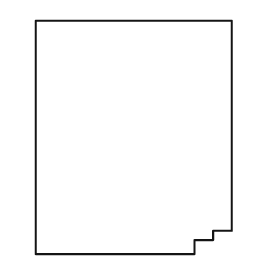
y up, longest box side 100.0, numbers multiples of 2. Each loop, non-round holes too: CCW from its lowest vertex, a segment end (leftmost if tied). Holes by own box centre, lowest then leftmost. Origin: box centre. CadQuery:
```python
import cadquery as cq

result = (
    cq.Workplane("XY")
    .moveTo(-42.0, -50.0)
    .lineTo(26.0, -50.0)
    .lineTo(26.0, -44.0)
    .lineTo(34.0, -44.0)
    .lineTo(34.0, -40.0)
    .lineTo(42.0, -40.0)
    .lineTo(42.0, 50.0)
    .lineTo(-42.0, 50.0)
    .close()
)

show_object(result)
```